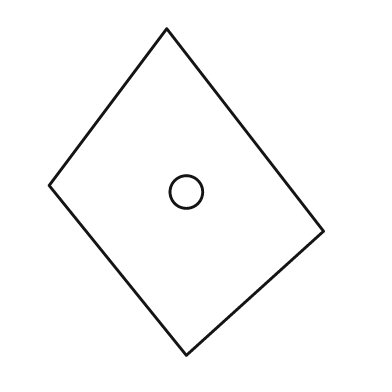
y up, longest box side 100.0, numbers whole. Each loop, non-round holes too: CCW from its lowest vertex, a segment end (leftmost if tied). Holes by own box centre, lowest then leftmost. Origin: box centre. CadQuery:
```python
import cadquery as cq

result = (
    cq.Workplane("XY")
    .moveTo(0.0, -50.0)
    .lineTo(42.0, -12.0)
    .lineTo(-6.0, 50.0)
    .lineTo(-42.0, 2.0)
    .close()
    .moveTo(0.0, 0.0)
    .circle(5.0)
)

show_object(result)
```